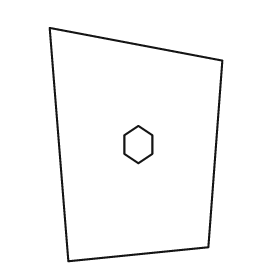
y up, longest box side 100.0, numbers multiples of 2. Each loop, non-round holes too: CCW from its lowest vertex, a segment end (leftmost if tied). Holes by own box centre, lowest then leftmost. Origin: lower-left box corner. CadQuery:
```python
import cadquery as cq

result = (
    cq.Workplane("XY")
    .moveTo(8.0, 0.0)
    .lineTo(68.0, 6.0)
    .lineTo(74.0, 86.0)
    .lineTo(0.0, 100.0)
    .close()
    .moveTo(38.0, 42.0)
    .lineTo(44.0, 46.0)
    .lineTo(44.0, 54.0)
    .lineTo(38.0, 58.0)
    .lineTo(32.0, 54.0)
    .lineTo(32.0, 46.0)
    .close()
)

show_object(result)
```